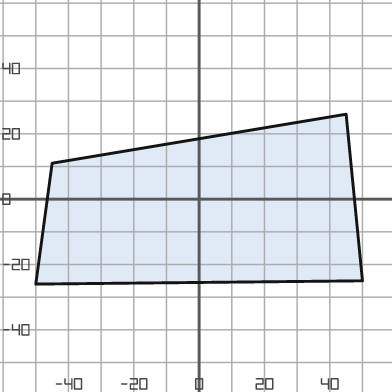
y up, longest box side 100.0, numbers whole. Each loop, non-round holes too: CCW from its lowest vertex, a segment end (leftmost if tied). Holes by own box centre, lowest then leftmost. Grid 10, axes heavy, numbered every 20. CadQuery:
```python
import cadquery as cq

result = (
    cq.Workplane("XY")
    .moveTo(-50.0, -26.0)
    .lineTo(50.0, -25.0)
    .lineTo(45.0, 26.0)
    .lineTo(-45.0, 11.0)
    .close()
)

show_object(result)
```